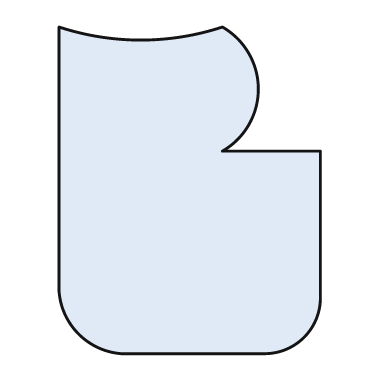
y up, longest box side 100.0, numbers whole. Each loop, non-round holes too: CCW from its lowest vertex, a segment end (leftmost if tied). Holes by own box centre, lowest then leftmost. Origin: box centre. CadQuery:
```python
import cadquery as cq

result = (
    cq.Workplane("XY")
    .moveTo(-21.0, -50.0)
    .lineTo(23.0, -50.0)
    .threePointArc((35.0, -45.0), (40.0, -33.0))
    .lineTo(40.0, 12.0)
    .lineTo(10.0, 12.0)
    .threePointArc((21.0, 31.0), (10.0, 50.0))
    .threePointArc((-15.0, 46.0), (-40.0, 50.0))
    .lineTo(-40.0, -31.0)
    .threePointArc((-34.0, -44.0), (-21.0, -50.0))
    .close()
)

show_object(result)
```